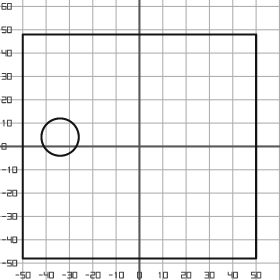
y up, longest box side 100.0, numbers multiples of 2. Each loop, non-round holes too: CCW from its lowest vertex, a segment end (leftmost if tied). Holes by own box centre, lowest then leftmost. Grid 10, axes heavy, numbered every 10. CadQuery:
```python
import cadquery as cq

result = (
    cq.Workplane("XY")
    .moveTo(-50.0, -48.0)
    .lineTo(50.0, -48.0)
    .lineTo(50.0, 48.0)
    .lineTo(-50.0, 48.0)
    .close()
    .moveTo(-34.0, 4.0)
    .circle(8.0)
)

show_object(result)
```